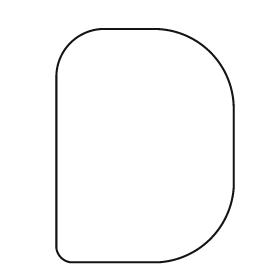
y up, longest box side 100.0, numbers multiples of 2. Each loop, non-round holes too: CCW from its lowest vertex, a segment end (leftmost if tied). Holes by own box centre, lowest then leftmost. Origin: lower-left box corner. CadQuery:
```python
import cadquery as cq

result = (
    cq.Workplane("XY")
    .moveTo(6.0, 0.0)
    .lineTo(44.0, 0.0)
    .threePointArc((66.0, 10.0), (76.0, 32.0))
    .lineTo(76.0, 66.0)
    .threePointArc((66.0, 90.0), (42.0, 100.0))
    .lineTo(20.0, 100.0)
    .threePointArc((6.0, 94.0), (0.0, 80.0))
    .lineTo(0.0, 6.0)
    .threePointArc((2.0, 2.0), (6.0, 0.0))
    .close()
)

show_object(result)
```